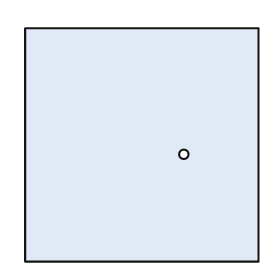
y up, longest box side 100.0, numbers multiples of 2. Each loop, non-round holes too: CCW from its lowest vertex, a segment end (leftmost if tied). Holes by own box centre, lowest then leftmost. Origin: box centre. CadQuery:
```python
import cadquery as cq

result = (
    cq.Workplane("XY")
    .moveTo(-50.0, -50.0)
    .lineTo(50.0, -50.0)
    .lineTo(50.0, 50.0)
    .lineTo(-50.0, 50.0)
    .close()
    .moveTo(18.0, -4.0)
    .circle(2.0)
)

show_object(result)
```